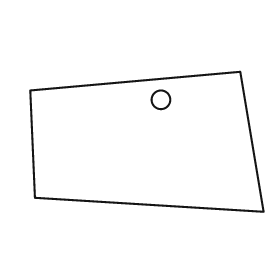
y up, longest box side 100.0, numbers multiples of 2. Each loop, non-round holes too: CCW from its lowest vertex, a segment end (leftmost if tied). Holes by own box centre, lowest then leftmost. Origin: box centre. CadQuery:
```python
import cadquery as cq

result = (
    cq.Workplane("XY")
    .moveTo(50.0, -30.0)
    .lineTo(40.0, 30.0)
    .lineTo(-50.0, 22.0)
    .lineTo(-48.0, -24.0)
    .close()
    .moveTo(6.0, 18.0)
    .circle(4.0)
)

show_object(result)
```